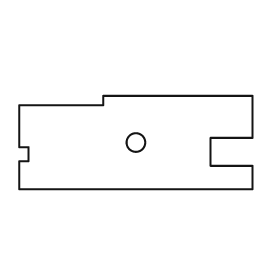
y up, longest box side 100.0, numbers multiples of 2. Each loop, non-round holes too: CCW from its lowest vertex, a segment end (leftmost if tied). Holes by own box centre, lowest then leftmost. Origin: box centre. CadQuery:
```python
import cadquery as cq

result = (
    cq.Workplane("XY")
    .moveTo(-50.0, -20.0)
    .lineTo(50.0, -20.0)
    .lineTo(50.0, -10.0)
    .lineTo(32.0, -10.0)
    .lineTo(32.0, 2.0)
    .lineTo(50.0, 2.0)
    .lineTo(50.0, 20.0)
    .lineTo(-14.0, 20.0)
    .lineTo(-14.0, 16.0)
    .lineTo(-50.0, 16.0)
    .lineTo(-50.0, -2.0)
    .lineTo(-46.0, -2.0)
    .lineTo(-46.0, -8.0)
    .lineTo(-50.0, -8.0)
    .close()
    .moveTo(0.0, 0.0)
    .circle(4.0)
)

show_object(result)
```